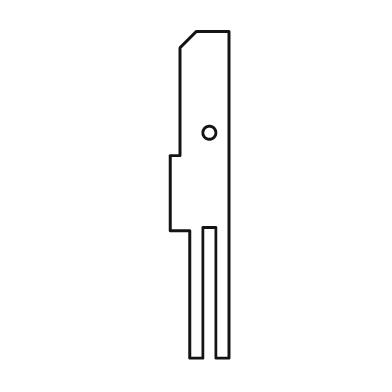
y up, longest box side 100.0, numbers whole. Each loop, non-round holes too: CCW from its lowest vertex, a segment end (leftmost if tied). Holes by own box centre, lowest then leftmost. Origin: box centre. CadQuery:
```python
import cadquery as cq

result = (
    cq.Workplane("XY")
    .moveTo(-3.0, -50.0)
    .lineTo(1.0, -50.0)
    .lineTo(1.0, -10.0)
    .lineTo(5.0, -10.0)
    .lineTo(5.0, -50.0)
    .lineTo(9.0, -50.0)
    .lineTo(9.0, 50.0)
    .lineTo(-1.0, 50.0)
    .lineTo(-6.0, 45.0)
    .lineTo(-6.0, 12.0)
    .lineTo(-9.0, 12.0)
    .lineTo(-9.0, -11.0)
    .lineTo(-3.0, -11.0)
    .close()
    .moveTo(3.0, 19.0)
    .circle(2.0)
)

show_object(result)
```